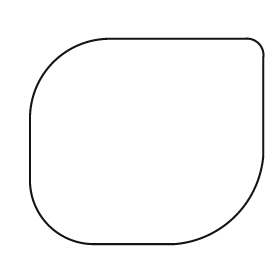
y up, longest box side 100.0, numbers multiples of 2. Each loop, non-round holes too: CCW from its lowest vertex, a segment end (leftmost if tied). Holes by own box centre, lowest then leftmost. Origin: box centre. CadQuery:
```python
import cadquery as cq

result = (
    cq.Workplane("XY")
    .moveTo(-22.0, -44.0)
    .lineTo(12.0, -44.0)
    .threePointArc((38.0, -32.0), (50.0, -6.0))
    .lineTo(50.0, 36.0)
    .threePointArc((48.0, 42.0), (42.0, 44.0))
    .lineTo(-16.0, 44.0)
    .threePointArc((-40.0, 34.0), (-50.0, 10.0))
    .lineTo(-50.0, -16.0)
    .threePointArc((-42.0, -36.0), (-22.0, -44.0))
    .close()
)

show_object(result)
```